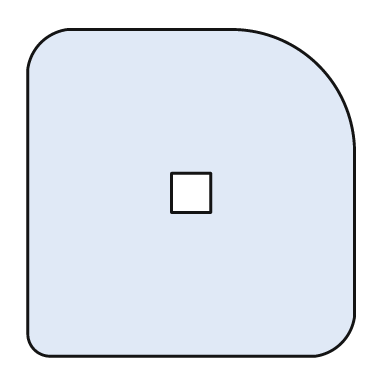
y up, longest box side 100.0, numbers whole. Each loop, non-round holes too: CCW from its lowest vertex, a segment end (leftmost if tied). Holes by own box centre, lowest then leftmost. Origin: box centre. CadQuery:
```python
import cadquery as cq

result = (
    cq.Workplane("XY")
    .moveTo(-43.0, -50.0)
    .lineTo(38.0, -50.0)
    .threePointArc((46.0, -46.0), (50.0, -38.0))
    .lineTo(50.0, 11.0)
    .threePointArc((39.0, 39.0), (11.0, 50.0))
    .lineTo(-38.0, 50.0)
    .threePointArc((-46.0, 46.0), (-50.0, 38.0))
    .lineTo(-50.0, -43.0)
    .threePointArc((-48.0, -48.0), (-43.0, -50.0))
    .close()
    .moveTo(-6.0, -6.0)
    .lineTo(6.0, -6.0)
    .lineTo(6.0, 6.0)
    .lineTo(-6.0, 6.0)
    .close()
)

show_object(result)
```